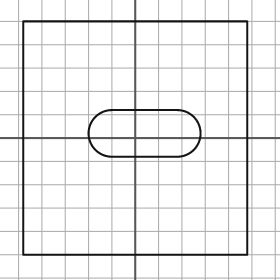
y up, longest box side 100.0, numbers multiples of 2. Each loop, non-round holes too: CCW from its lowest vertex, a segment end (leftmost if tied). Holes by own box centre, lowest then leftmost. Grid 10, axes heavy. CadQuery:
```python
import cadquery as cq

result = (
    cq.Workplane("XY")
    .moveTo(-48.0, -50.0)
    .lineTo(48.0, -50.0)
    .lineTo(48.0, 50.0)
    .lineTo(-48.0, 50.0)
    .close()
    .moveTo(-10.0, -8.0)
    .lineTo(18.0, -8.0)
    .threePointArc((28.0, 2.0), (18.0, 12.0))
    .lineTo(-10.0, 12.0)
    .threePointArc((-20.0, 2.0), (-10.0, -8.0))
    .close()
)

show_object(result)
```